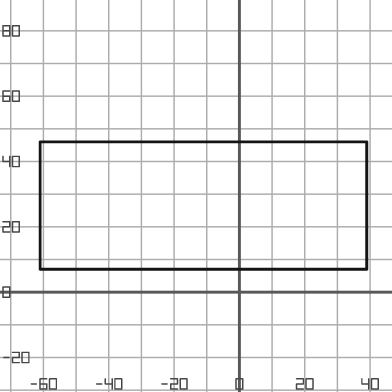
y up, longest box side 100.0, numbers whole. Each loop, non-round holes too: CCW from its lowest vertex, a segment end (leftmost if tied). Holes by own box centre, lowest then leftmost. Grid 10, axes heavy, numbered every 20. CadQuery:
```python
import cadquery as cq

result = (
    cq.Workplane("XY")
    .moveTo(-61.0, 7.0)
    .lineTo(39.0, 7.0)
    .lineTo(39.0, 46.0)
    .lineTo(-61.0, 46.0)
    .close()
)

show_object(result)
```